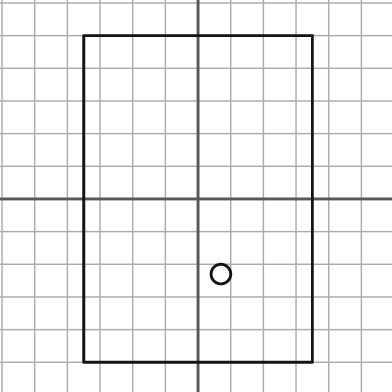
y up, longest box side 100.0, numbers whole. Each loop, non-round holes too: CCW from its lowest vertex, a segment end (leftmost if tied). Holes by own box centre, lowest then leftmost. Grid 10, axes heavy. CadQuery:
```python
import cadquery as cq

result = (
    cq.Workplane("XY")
    .moveTo(-35.0, -50.0)
    .lineTo(35.0, -50.0)
    .lineTo(35.0, 50.0)
    .lineTo(-35.0, 50.0)
    .close()
    .moveTo(7.0, -23.0)
    .circle(3.0)
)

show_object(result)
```